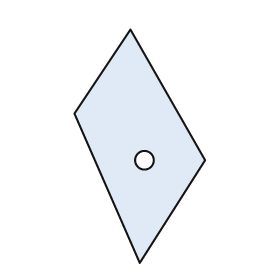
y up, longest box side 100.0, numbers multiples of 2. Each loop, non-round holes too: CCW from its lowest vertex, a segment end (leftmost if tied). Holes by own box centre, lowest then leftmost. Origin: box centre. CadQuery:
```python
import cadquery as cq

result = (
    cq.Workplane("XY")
    .moveTo(0.0, -50.0)
    .lineTo(28.0, -6.0)
    .lineTo(-4.0, 50.0)
    .lineTo(-28.0, 14.0)
    .close()
    .moveTo(2.0, -6.0)
    .circle(4.0)
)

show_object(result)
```